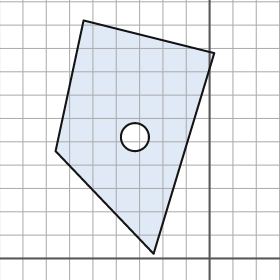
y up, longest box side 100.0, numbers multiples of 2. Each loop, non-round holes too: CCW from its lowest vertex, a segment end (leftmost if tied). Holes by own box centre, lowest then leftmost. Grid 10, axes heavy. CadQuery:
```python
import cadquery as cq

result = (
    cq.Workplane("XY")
    .moveTo(-24.0, 2.0)
    .lineTo(2.0, 88.0)
    .lineTo(-54.0, 102.0)
    .lineTo(-66.0, 46.0)
    .close()
    .moveTo(-32.0, 52.0)
    .circle(6.0)
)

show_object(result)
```